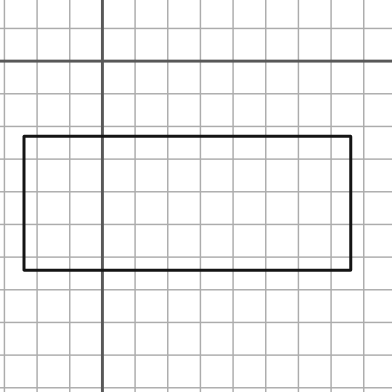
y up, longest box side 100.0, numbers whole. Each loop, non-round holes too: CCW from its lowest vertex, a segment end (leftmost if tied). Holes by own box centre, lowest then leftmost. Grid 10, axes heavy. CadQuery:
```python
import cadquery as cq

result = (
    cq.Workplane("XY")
    .moveTo(-24.0, -64.0)
    .lineTo(76.0, -64.0)
    .lineTo(76.0, -23.0)
    .lineTo(-24.0, -23.0)
    .close()
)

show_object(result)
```